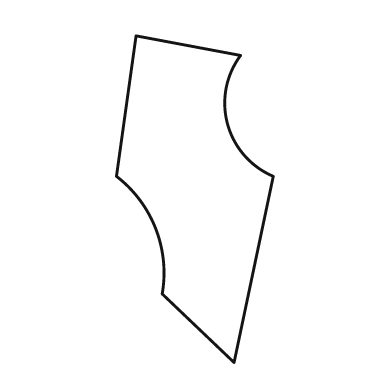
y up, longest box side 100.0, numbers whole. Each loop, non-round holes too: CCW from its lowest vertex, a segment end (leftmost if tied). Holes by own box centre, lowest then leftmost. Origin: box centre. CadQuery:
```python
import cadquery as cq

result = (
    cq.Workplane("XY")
    .moveTo(12.0, -50.0)
    .lineTo(24.0, 7.0)
    .threePointArc((10.0, 23.0), (14.0, 44.0))
    .lineTo(-18.0, 50.0)
    .lineTo(-24.0, 7.0)
    .threePointArc((-12.0, -9.0), (-10.0, -29.0))
    .close()
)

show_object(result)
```